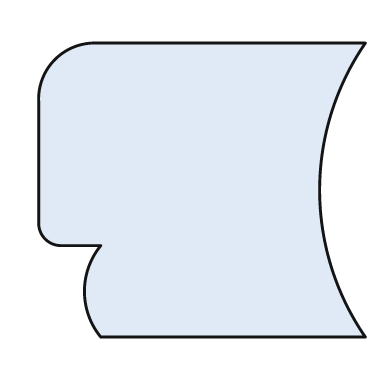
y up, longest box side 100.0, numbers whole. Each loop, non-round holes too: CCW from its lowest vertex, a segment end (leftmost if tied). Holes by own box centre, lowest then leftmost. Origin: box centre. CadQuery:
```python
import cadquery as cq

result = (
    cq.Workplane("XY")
    .moveTo(-31.0, -45.0)
    .lineTo(50.0, -45.0)
    .threePointArc((36.0, 0.0), (50.0, 45.0))
    .lineTo(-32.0, 45.0)
    .threePointArc((-45.0, 40.0), (-50.0, 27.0))
    .lineTo(-50.0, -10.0)
    .threePointArc((-48.0, -15.0), (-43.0, -17.0))
    .lineTo(-31.0, -17.0)
    .threePointArc((-36.0, -31.0), (-31.0, -45.0))
    .close()
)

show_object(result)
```